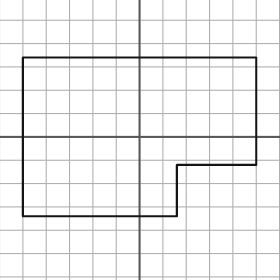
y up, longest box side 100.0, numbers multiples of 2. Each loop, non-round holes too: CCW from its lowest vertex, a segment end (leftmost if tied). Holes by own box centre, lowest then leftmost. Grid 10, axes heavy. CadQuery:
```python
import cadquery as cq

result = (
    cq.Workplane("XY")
    .moveTo(-50.0, -34.0)
    .lineTo(16.0, -34.0)
    .lineTo(16.0, -12.0)
    .lineTo(50.0, -12.0)
    .lineTo(50.0, 34.0)
    .lineTo(-50.0, 34.0)
    .close()
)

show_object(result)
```